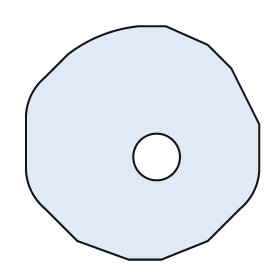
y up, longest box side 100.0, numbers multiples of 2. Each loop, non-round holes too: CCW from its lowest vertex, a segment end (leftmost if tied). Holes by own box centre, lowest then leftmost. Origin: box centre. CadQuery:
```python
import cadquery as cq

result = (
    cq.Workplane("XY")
    .moveTo(-6.0, -50.0)
    .lineTo(8.0, -50.0)
    .lineTo(28.0, -42.0)
    .lineTo(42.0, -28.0)
    .threePointArc((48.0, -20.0), (50.0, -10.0))
    .lineTo(50.0, 8.0)
    .lineTo(38.0, 32.0)
    .lineTo(28.0, 42.0)
    .lineTo(10.0, 50.0)
    .lineTo(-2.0, 50.0)
    .threePointArc((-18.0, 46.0), (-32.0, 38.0))
    .lineTo(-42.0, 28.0)
    .threePointArc((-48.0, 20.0), (-50.0, 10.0))
    .lineTo(-50.0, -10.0)
    .threePointArc((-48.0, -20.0), (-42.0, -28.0))
    .lineTo(-28.0, -42.0)
    .close()
    .moveTo(6.0, -6.0)
    .circle(10.0)
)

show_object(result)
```